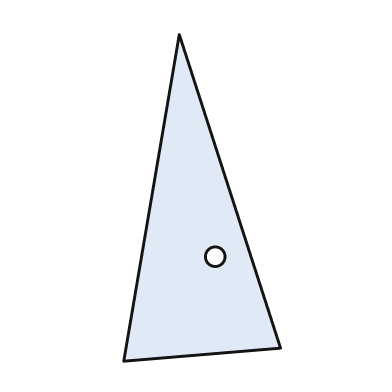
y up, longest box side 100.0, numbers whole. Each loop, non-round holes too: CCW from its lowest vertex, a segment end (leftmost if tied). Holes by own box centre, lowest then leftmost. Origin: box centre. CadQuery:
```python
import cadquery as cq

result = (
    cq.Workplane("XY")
    .moveTo(-24.0, -50.0)
    .lineTo(24.0, -46.0)
    .lineTo(-7.0, 50.0)
    .close()
    .moveTo(4.0, -18.0)
    .circle(3.0)
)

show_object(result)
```